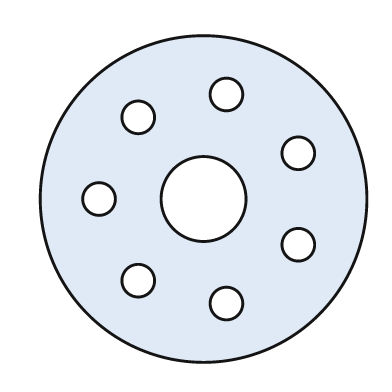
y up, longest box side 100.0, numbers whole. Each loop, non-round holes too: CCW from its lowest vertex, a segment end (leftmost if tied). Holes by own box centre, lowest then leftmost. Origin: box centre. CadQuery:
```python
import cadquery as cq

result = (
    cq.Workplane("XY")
    .moveTo(0.0, 0.0)
    .circle(50.0)
    .moveTo(7.0, -32.0)
    .circle(5.0)
    .moveTo(-20.0, -25.0)
    .circle(5.0)
    .moveTo(29.0, -14.0)
    .circle(5.0)
    .moveTo(-32.0, 0.0)
    .circle(5.0)
    .moveTo(0.0, 0.0)
    .circle(13.0)
    .moveTo(29.0, 14.0)
    .circle(5.0)
    .moveTo(-20.0, 25.0)
    .circle(5.0)
    .moveTo(7.0, 32.0)
    .circle(5.0)
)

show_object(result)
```